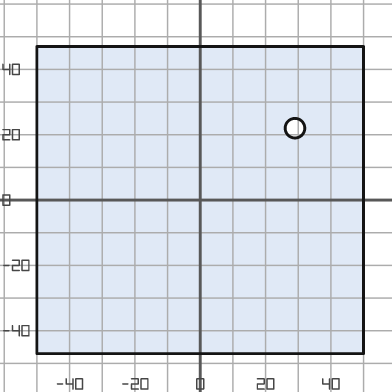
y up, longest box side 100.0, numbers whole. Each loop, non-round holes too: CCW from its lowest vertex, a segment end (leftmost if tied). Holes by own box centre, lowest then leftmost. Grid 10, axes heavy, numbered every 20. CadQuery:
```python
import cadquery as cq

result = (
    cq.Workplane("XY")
    .moveTo(-50.0, -47.0)
    .lineTo(50.0, -47.0)
    .lineTo(50.0, 47.0)
    .lineTo(-50.0, 47.0)
    .close()
    .moveTo(29.0, 22.0)
    .circle(3.0)
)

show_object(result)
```